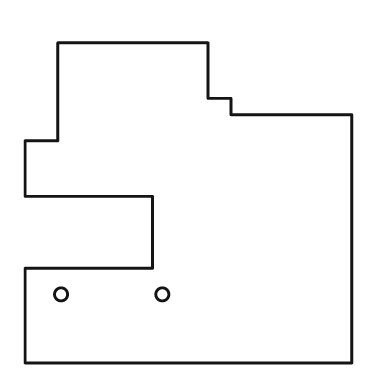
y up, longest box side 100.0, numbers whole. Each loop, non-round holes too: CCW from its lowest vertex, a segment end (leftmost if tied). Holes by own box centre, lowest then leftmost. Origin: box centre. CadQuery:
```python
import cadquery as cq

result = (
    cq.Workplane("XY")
    .moveTo(-50.0, -49.0)
    .lineTo(50.0, -49.0)
    .lineTo(50.0, 27.0)
    .lineTo(13.0, 27.0)
    .lineTo(13.0, 32.0)
    .lineTo(6.0, 32.0)
    .lineTo(6.0, 49.0)
    .lineTo(-40.0, 49.0)
    .lineTo(-40.0, 19.0)
    .lineTo(-50.0, 19.0)
    .lineTo(-50.0, 2.0)
    .lineTo(-11.0, 2.0)
    .lineTo(-11.0, -20.0)
    .lineTo(-50.0, -20.0)
    .close()
    .moveTo(-39.0, -28.0)
    .circle(2.0)
    .moveTo(-8.0, -28.0)
    .circle(2.0)
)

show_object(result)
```